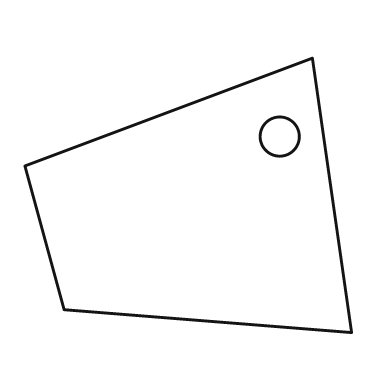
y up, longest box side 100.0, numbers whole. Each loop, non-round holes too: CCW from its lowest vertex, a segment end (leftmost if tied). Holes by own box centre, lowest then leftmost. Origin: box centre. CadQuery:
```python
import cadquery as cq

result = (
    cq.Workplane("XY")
    .moveTo(50.0, -42.0)
    .lineTo(38.0, 42.0)
    .lineTo(-50.0, 9.0)
    .lineTo(-38.0, -35.0)
    .close()
    .moveTo(28.0, 18.0)
    .circle(6.0)
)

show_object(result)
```